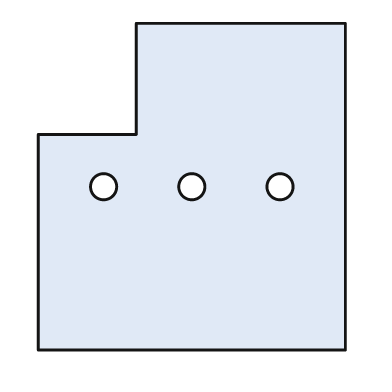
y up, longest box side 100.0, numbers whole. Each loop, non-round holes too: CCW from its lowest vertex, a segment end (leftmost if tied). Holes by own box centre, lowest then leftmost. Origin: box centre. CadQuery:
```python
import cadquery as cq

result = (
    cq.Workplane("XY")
    .moveTo(-47.0, -50.0)
    .lineTo(47.0, -50.0)
    .lineTo(47.0, 50.0)
    .lineTo(-17.0, 50.0)
    .lineTo(-17.0, 16.0)
    .lineTo(-47.0, 16.0)
    .close()
    .moveTo(-27.0, 0.0)
    .circle(4.0)
    .moveTo(0.0, 0.0)
    .circle(4.0)
    .moveTo(27.0, 0.0)
    .circle(4.0)
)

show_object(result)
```